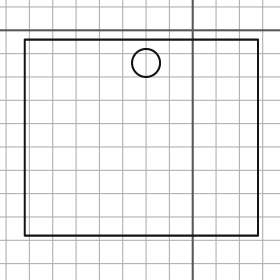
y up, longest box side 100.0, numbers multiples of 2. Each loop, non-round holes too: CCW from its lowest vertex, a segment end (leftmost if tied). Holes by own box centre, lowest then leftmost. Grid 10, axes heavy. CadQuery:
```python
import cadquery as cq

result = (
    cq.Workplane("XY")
    .moveTo(-72.0, -88.0)
    .lineTo(28.0, -88.0)
    .lineTo(28.0, -4.0)
    .lineTo(-72.0, -4.0)
    .close()
    .moveTo(-20.0, -14.0)
    .circle(6.0)
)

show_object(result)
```